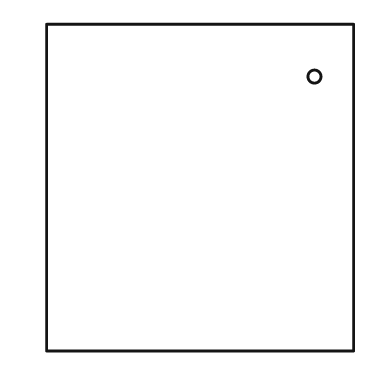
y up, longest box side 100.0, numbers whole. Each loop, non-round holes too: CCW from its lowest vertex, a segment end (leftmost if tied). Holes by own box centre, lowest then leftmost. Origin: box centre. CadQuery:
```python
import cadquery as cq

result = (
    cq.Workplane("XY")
    .moveTo(-47.0, -50.0)
    .lineTo(47.0, -50.0)
    .lineTo(47.0, 50.0)
    .lineTo(-47.0, 50.0)
    .close()
    .moveTo(35.0, 34.0)
    .circle(2.0)
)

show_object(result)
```